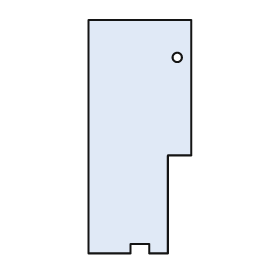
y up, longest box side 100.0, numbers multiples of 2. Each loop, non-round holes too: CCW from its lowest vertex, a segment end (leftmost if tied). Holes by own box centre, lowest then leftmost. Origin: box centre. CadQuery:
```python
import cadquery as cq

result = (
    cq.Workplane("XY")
    .moveTo(-22.0, -50.0)
    .lineTo(-4.0, -50.0)
    .lineTo(-4.0, -46.0)
    .lineTo(4.0, -46.0)
    .lineTo(4.0, -50.0)
    .lineTo(12.0, -50.0)
    .lineTo(12.0, -8.0)
    .lineTo(22.0, -8.0)
    .lineTo(22.0, 50.0)
    .lineTo(-22.0, 50.0)
    .close()
    .moveTo(16.0, 34.0)
    .circle(2.0)
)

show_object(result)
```